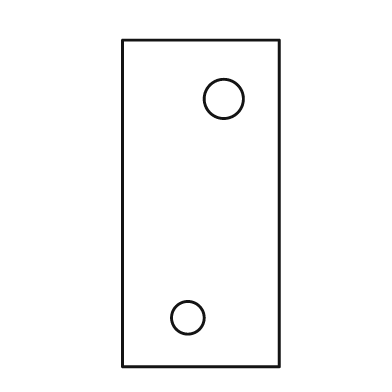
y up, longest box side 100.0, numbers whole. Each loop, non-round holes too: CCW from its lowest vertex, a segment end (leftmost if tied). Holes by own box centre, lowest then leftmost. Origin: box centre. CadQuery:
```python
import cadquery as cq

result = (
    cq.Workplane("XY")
    .moveTo(-24.0, -50.0)
    .lineTo(24.0, -50.0)
    .lineTo(24.0, 50.0)
    .lineTo(-24.0, 50.0)
    .close()
    .moveTo(-4.0, -35.0)
    .circle(5.0)
    .moveTo(7.0, 32.0)
    .circle(6.0)
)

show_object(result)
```